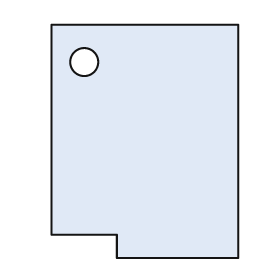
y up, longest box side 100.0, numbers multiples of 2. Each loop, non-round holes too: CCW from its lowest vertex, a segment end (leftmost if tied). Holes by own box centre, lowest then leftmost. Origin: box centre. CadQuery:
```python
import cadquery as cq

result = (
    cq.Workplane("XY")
    .moveTo(-12.0, -50.0)
    .lineTo(40.0, -50.0)
    .lineTo(40.0, 50.0)
    .lineTo(-40.0, 50.0)
    .lineTo(-40.0, -40.0)
    .lineTo(-12.0, -40.0)
    .close()
    .moveTo(-26.0, 34.0)
    .circle(6.0)
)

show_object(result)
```